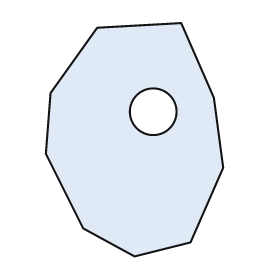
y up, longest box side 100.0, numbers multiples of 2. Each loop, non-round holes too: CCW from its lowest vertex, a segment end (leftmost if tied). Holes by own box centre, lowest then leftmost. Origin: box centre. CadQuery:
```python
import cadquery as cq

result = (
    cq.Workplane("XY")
    .moveTo(0.0, -50.0)
    .lineTo(24.0, -44.0)
    .lineTo(38.0, -12.0)
    .lineTo(34.0, 18.0)
    .lineTo(20.0, 50.0)
    .lineTo(-16.0, 48.0)
    .lineTo(-36.0, 20.0)
    .lineTo(-38.0, -6.0)
    .lineTo(-22.0, -38.0)
    .close()
    .moveTo(8.0, 12.0)
    .circle(10.0)
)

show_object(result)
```